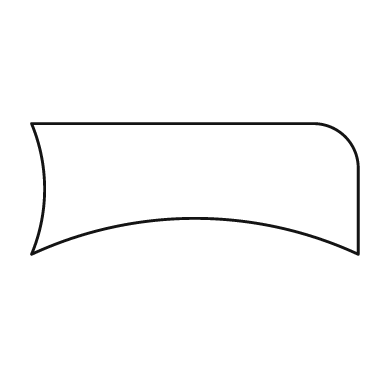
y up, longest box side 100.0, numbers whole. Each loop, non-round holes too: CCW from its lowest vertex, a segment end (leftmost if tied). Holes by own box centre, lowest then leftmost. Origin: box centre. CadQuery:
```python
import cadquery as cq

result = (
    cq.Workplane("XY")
    .moveTo(-50.0, -20.0)
    .threePointArc((0.0, -9.0), (50.0, -20.0))
    .lineTo(50.0, 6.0)
    .threePointArc((46.0, 16.0), (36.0, 20.0))
    .lineTo(-50.0, 20.0)
    .threePointArc((-46.0, 0.0), (-50.0, -20.0))
    .close()
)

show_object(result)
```